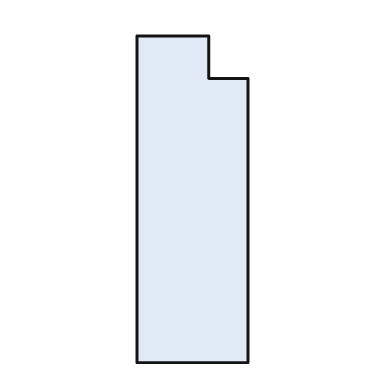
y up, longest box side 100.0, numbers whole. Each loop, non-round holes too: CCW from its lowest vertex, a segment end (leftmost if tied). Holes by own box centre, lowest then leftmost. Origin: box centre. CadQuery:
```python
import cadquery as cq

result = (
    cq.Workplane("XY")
    .moveTo(-17.0, -50.0)
    .lineTo(17.0, -50.0)
    .lineTo(17.0, 37.0)
    .lineTo(5.0, 37.0)
    .lineTo(5.0, 50.0)
    .lineTo(-17.0, 50.0)
    .close()
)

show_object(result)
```